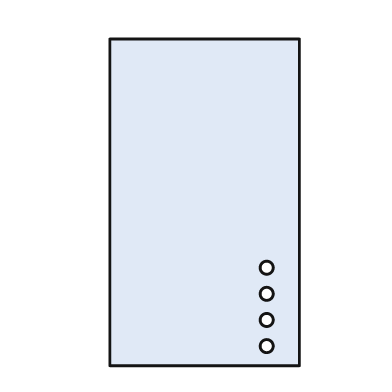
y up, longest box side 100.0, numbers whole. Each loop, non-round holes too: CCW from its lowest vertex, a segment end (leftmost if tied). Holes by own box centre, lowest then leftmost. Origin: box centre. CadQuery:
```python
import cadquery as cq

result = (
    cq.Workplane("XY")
    .moveTo(-29.0, -50.0)
    .lineTo(29.0, -50.0)
    .lineTo(29.0, 50.0)
    .lineTo(-29.0, 50.0)
    .close()
    .moveTo(19.0, -44.0)
    .circle(2.0)
    .moveTo(19.0, -36.0)
    .circle(2.0)
    .moveTo(19.0, -28.0)
    .circle(2.0)
    .moveTo(19.0, -20.0)
    .circle(2.0)
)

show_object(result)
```